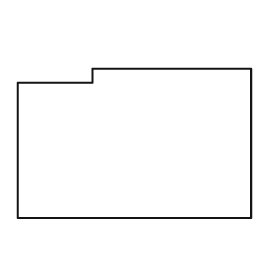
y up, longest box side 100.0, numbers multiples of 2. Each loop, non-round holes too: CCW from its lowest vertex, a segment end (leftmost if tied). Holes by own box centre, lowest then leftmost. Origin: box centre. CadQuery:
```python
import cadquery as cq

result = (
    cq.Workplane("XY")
    .moveTo(-50.0, -32.0)
    .lineTo(50.0, -32.0)
    .lineTo(50.0, 32.0)
    .lineTo(-18.0, 32.0)
    .lineTo(-18.0, 26.0)
    .lineTo(-50.0, 26.0)
    .close()
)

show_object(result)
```